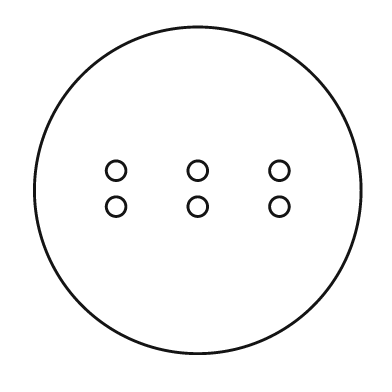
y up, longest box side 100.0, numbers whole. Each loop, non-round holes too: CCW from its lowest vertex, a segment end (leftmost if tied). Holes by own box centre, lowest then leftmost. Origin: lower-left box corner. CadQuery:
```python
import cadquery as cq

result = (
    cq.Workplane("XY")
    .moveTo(50.0, 50.0)
    .circle(50.0)
    .moveTo(25.0, 45.0)
    .circle(3.0)
    .moveTo(50.0, 45.0)
    .circle(3.0)
    .moveTo(75.0, 45.0)
    .circle(3.0)
    .moveTo(25.0, 56.0)
    .circle(3.0)
    .moveTo(50.0, 56.0)
    .circle(3.0)
    .moveTo(75.0, 56.0)
    .circle(3.0)
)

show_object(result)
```